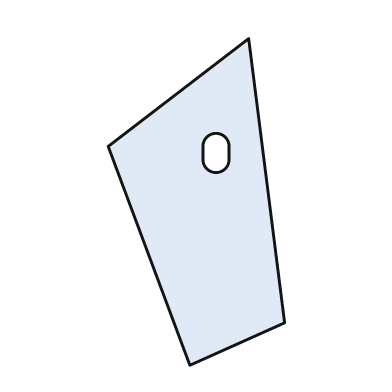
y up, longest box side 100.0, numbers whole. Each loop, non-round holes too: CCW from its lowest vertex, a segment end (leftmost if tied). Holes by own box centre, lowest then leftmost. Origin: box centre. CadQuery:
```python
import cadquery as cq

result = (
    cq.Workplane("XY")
    .moveTo(-2.0, -50.0)
    .lineTo(27.0, -37.0)
    .lineTo(16.0, 50.0)
    .lineTo(-27.0, 17.0)
    .close()
    .moveTo(2.0, 13.0)
    .threePointArc((6.0, 9.0), (10.0, 13.0))
    .lineTo(10.0, 17.0)
    .threePointArc((6.0, 21.0), (2.0, 17.0))
    .close()
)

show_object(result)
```